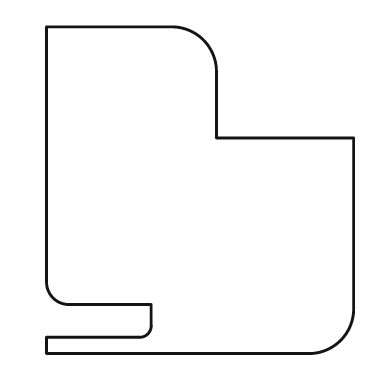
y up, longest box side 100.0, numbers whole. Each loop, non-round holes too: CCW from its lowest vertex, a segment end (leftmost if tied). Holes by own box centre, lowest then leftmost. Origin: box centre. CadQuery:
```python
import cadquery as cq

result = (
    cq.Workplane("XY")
    .moveTo(-47.0, -50.0)
    .lineTo(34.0, -50.0)
    .threePointArc((43.0, -46.0), (47.0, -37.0))
    .lineTo(47.0, 16.0)
    .lineTo(5.0, 16.0)
    .lineTo(5.0, 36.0)
    .threePointArc((1.0, 46.0), (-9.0, 50.0))
    .lineTo(-47.0, 50.0)
    .lineTo(-47.0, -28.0)
    .threePointArc((-45.0, -33.0), (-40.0, -35.0))
    .lineTo(-15.0, -35.0)
    .lineTo(-15.0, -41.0)
    .threePointArc((-16.0, -44.0), (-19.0, -45.0))
    .lineTo(-47.0, -45.0)
    .close()
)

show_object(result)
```